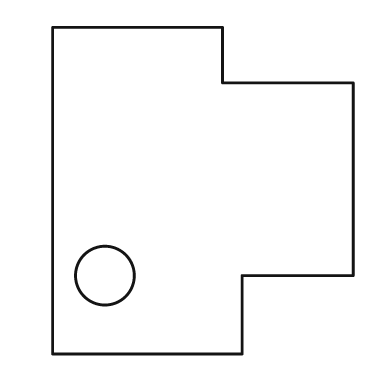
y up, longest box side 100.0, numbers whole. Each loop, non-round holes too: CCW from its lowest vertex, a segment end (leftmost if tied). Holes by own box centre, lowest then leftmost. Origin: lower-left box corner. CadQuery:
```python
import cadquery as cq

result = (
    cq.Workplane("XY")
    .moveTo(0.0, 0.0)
    .lineTo(58.0, 0.0)
    .lineTo(58.0, 24.0)
    .lineTo(92.0, 24.0)
    .lineTo(92.0, 83.0)
    .lineTo(52.0, 83.0)
    .lineTo(52.0, 100.0)
    .lineTo(0.0, 100.0)
    .close()
    .moveTo(16.0, 24.0)
    .circle(9.0)
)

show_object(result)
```